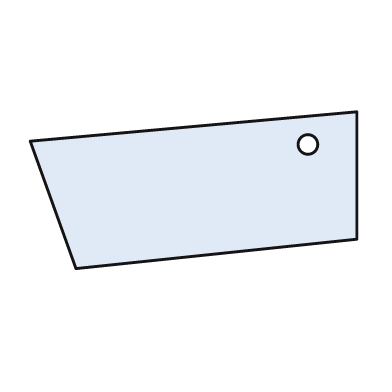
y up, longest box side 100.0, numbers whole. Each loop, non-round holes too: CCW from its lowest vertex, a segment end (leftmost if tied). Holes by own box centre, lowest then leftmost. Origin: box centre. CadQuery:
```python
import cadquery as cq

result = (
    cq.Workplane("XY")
    .moveTo(-36.0, -24.0)
    .lineTo(50.0, -15.0)
    .lineTo(50.0, 24.0)
    .lineTo(-50.0, 15.0)
    .close()
    .moveTo(35.0, 14.0)
    .circle(3.0)
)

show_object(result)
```